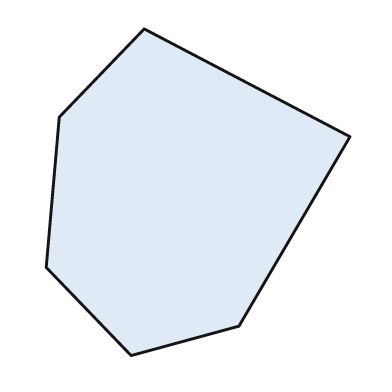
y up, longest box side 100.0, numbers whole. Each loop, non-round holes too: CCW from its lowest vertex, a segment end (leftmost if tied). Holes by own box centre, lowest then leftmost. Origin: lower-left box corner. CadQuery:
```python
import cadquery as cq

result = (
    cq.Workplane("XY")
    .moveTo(26.0, 0.0)
    .lineTo(59.0, 9.0)
    .lineTo(93.0, 67.0)
    .lineTo(30.0, 100.0)
    .lineTo(4.0, 73.0)
    .lineTo(0.0, 27.0)
    .close()
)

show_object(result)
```